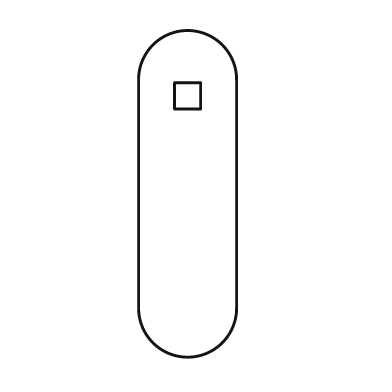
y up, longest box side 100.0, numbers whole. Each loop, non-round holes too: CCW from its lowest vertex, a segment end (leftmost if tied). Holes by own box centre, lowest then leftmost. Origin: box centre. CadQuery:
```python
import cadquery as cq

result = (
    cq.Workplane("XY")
    .moveTo(-15.0, -35.0)
    .threePointArc((0.0, -50.0), (15.0, -35.0))
    .lineTo(15.0, 35.0)
    .threePointArc((0.0, 50.0), (-15.0, 35.0))
    .close()
    .moveTo(-4.0, 26.0)
    .lineTo(4.0, 26.0)
    .lineTo(4.0, 34.0)
    .lineTo(-4.0, 34.0)
    .close()
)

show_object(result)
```